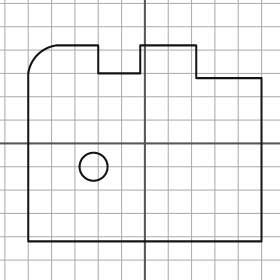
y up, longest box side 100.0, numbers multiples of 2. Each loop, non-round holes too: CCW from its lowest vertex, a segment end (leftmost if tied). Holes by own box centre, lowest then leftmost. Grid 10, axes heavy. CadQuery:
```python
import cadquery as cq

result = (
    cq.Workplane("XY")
    .moveTo(-50.0, -42.0)
    .lineTo(50.0, -42.0)
    .lineTo(50.0, 28.0)
    .lineTo(22.0, 28.0)
    .lineTo(22.0, 42.0)
    .lineTo(-2.0, 42.0)
    .lineTo(-2.0, 30.0)
    .lineTo(-20.0, 30.0)
    .lineTo(-20.0, 42.0)
    .lineTo(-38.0, 42.0)
    .threePointArc((-46.0, 38.0), (-50.0, 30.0))
    .close()
    .moveTo(-22.0, -10.0)
    .circle(6.0)
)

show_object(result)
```